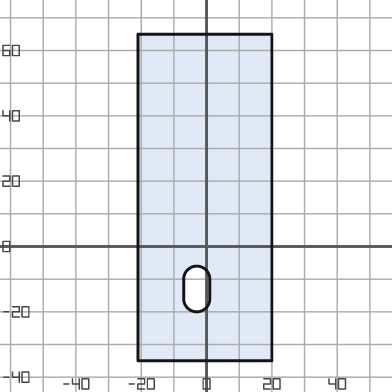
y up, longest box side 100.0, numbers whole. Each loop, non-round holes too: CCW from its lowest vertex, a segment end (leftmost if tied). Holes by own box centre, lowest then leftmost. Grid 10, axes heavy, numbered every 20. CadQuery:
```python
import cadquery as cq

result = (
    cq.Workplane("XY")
    .moveTo(-21.0, -35.0)
    .lineTo(20.0, -35.0)
    .lineTo(20.0, 65.0)
    .lineTo(-21.0, 65.0)
    .close()
    .moveTo(-7.0, -16.0)
    .threePointArc((-3.0, -20.0), (1.0, -16.0))
    .lineTo(1.0, -10.0)
    .threePointArc((-3.0, -6.0), (-7.0, -10.0))
    .close()
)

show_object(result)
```